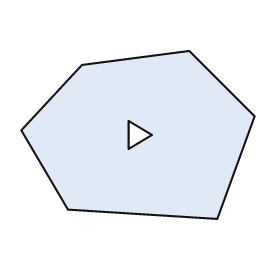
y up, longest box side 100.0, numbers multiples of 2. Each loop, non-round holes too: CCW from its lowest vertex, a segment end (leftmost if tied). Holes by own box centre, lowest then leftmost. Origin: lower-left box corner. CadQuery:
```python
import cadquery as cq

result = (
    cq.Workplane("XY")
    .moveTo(84.0, 0.0)
    .lineTo(100.0, 44.0)
    .lineTo(72.0, 72.0)
    .lineTo(26.0, 66.0)
    .lineTo(0.0, 38.0)
    .lineTo(20.0, 4.0)
    .close()
    .moveTo(46.0, 30.0)
    .lineTo(56.0, 36.0)
    .lineTo(46.0, 42.0)
    .close()
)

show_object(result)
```